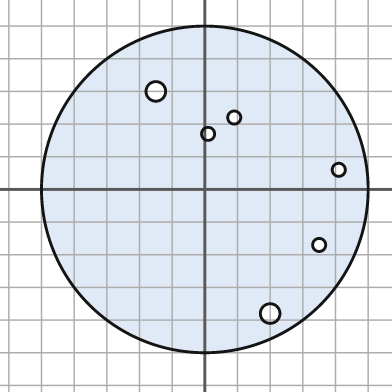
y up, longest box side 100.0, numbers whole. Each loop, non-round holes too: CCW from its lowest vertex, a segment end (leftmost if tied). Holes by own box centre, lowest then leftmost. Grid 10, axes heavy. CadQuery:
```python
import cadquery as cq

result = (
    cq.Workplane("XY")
    .moveTo(0.0, 0.0)
    .circle(50.0)
    .moveTo(20.0, -38.0)
    .circle(3.0)
    .moveTo(35.0, -17.0)
    .circle(2.0)
    .moveTo(41.0, 6.0)
    .circle(2.0)
    .moveTo(1.0, 17.0)
    .circle(2.0)
    .moveTo(9.0, 22.0)
    .circle(2.0)
    .moveTo(-15.0, 30.0)
    .circle(3.0)
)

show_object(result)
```